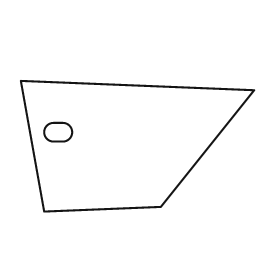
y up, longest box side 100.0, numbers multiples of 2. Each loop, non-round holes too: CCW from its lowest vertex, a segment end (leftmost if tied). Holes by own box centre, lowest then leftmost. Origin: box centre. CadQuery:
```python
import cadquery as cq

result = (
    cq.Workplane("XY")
    .moveTo(-40.0, -28.0)
    .lineTo(10.0, -26.0)
    .lineTo(50.0, 24.0)
    .lineTo(-50.0, 28.0)
    .close()
    .moveTo(-36.0, 2.0)
    .lineTo(-32.0, 2.0)
    .threePointArc((-28.0, 6.0), (-32.0, 10.0))
    .lineTo(-36.0, 10.0)
    .threePointArc((-40.0, 6.0), (-36.0, 2.0))
    .close()
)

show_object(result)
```